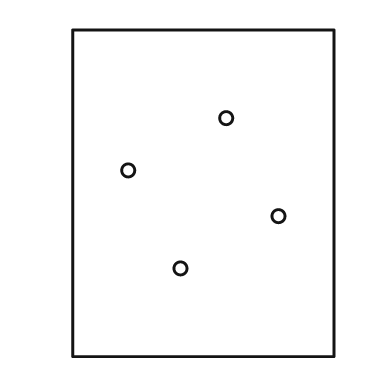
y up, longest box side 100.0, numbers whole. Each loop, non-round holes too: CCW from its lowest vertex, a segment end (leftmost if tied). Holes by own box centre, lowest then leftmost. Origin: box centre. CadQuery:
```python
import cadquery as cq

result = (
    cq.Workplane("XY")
    .moveTo(-40.0, -50.0)
    .lineTo(40.0, -50.0)
    .lineTo(40.0, 50.0)
    .lineTo(-40.0, 50.0)
    .close()
    .moveTo(-7.0, -23.0)
    .circle(2.0)
    .moveTo(23.0, -7.0)
    .circle(2.0)
    .moveTo(-23.0, 7.0)
    .circle(2.0)
    .moveTo(7.0, 23.0)
    .circle(2.0)
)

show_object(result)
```